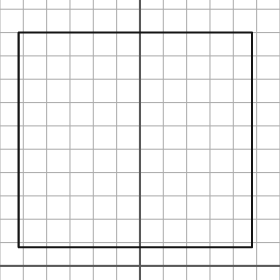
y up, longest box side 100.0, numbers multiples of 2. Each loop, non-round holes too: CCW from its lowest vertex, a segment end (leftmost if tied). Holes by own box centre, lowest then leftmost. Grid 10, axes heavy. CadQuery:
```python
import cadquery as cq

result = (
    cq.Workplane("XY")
    .moveTo(-52.0, 8.0)
    .lineTo(48.0, 8.0)
    .lineTo(48.0, 100.0)
    .lineTo(-52.0, 100.0)
    .close()
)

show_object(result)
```